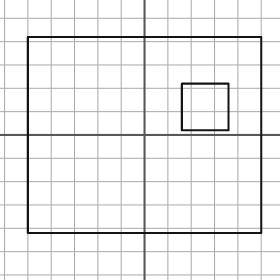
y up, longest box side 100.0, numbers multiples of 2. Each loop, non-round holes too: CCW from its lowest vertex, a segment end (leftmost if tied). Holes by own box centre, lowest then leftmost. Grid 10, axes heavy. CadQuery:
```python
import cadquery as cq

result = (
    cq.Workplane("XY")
    .moveTo(-50.0, -42.0)
    .lineTo(50.0, -42.0)
    .lineTo(50.0, 42.0)
    .lineTo(-50.0, 42.0)
    .close()
    .moveTo(16.0, 2.0)
    .lineTo(36.0, 2.0)
    .lineTo(36.0, 22.0)
    .lineTo(16.0, 22.0)
    .close()
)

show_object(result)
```